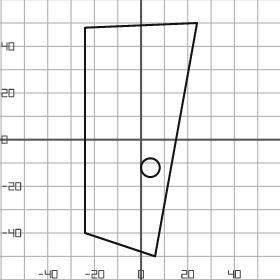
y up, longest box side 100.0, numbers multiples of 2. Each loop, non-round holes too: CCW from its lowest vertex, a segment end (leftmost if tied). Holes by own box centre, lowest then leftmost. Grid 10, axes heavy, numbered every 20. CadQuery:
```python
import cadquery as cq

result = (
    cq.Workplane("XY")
    .moveTo(6.0, -50.0)
    .lineTo(24.0, 50.0)
    .lineTo(-24.0, 48.0)
    .lineTo(-24.0, -40.0)
    .close()
    .moveTo(4.0, -12.0)
    .circle(4.0)
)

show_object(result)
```